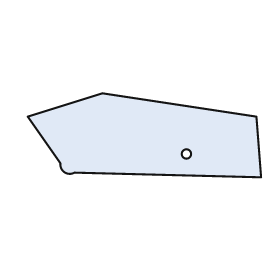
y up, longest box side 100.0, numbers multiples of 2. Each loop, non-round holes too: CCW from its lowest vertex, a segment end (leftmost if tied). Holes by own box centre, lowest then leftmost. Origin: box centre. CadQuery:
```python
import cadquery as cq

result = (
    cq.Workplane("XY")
    .moveTo(50.0, -18.0)
    .lineTo(48.0, 8.0)
    .lineTo(-18.0, 18.0)
    .lineTo(-50.0, 8.0)
    .lineTo(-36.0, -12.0)
    .threePointArc((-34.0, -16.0), (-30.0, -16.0))
    .close()
    .moveTo(18.0, -8.0)
    .circle(2.0)
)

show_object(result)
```